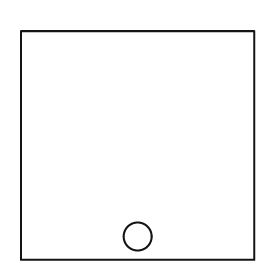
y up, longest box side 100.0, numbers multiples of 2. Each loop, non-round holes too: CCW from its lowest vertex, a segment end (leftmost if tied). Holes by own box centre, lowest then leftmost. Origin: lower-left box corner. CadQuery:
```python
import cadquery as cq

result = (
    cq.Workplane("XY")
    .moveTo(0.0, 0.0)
    .lineTo(100.0, 0.0)
    .lineTo(100.0, 98.0)
    .lineTo(0.0, 98.0)
    .close()
    .moveTo(50.0, 10.0)
    .circle(6.0)
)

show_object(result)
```